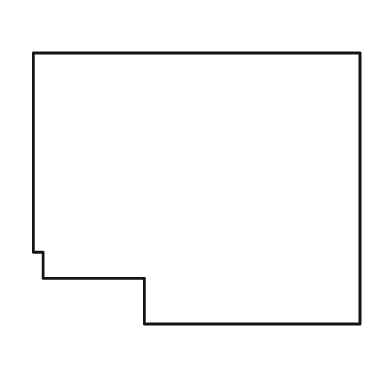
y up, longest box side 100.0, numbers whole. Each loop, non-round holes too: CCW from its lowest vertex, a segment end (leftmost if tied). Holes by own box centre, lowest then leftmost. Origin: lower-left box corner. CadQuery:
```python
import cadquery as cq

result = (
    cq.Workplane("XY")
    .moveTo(34.0, 0.0)
    .lineTo(100.0, 0.0)
    .lineTo(100.0, 83.0)
    .lineTo(0.0, 83.0)
    .lineTo(0.0, 22.0)
    .lineTo(3.0, 22.0)
    .lineTo(3.0, 14.0)
    .lineTo(34.0, 14.0)
    .close()
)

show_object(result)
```